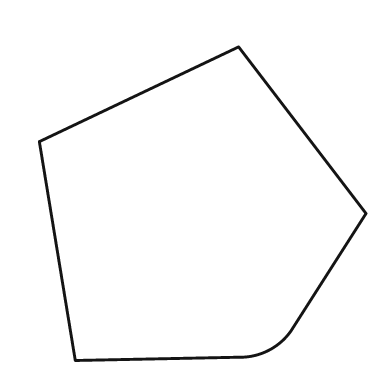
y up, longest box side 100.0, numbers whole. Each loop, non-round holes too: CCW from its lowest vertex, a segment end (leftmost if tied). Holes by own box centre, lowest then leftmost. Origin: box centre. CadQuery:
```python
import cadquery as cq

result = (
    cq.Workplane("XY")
    .moveTo(-39.0, -48.0)
    .lineTo(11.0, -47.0)
    .threePointArc((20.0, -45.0), (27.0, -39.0))
    .lineTo(50.0, -3.0)
    .lineTo(11.0, 48.0)
    .lineTo(-50.0, 19.0)
    .close()
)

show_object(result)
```